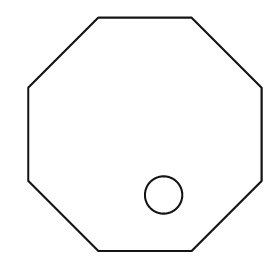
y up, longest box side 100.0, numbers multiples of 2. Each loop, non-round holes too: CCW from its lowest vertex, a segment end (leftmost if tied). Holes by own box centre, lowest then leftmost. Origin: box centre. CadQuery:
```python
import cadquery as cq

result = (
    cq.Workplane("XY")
    .moveTo(-20.0, -50.0)
    .lineTo(20.0, -50.0)
    .lineTo(50.0, -20.0)
    .lineTo(50.0, 20.0)
    .lineTo(20.0, 50.0)
    .lineTo(-20.0, 50.0)
    .lineTo(-50.0, 20.0)
    .lineTo(-50.0, -20.0)
    .close()
    .moveTo(8.0, -26.0)
    .circle(8.0)
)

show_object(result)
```